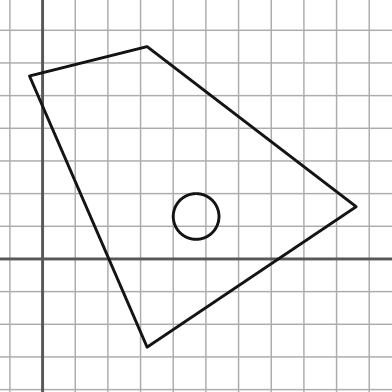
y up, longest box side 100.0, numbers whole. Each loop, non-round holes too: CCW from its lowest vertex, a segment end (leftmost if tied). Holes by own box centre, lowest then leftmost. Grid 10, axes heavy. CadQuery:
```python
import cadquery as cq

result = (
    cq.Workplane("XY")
    .moveTo(32.0, -27.0)
    .lineTo(96.0, 16.0)
    .lineTo(32.0, 65.0)
    .lineTo(-4.0, 56.0)
    .close()
    .moveTo(47.0, 13.0)
    .circle(7.0)
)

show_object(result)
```